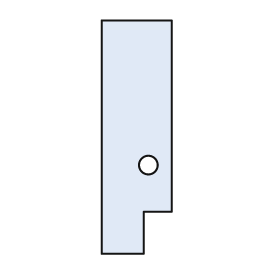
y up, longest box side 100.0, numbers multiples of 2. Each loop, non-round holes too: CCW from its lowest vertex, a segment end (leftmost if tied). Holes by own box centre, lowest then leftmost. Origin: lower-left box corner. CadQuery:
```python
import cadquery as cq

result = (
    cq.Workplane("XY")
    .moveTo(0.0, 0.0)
    .lineTo(18.0, 0.0)
    .lineTo(18.0, 18.0)
    .lineTo(30.0, 18.0)
    .lineTo(30.0, 100.0)
    .lineTo(0.0, 100.0)
    .close()
    .moveTo(20.0, 38.0)
    .circle(4.0)
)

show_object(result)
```